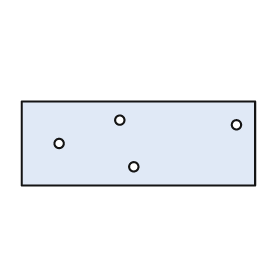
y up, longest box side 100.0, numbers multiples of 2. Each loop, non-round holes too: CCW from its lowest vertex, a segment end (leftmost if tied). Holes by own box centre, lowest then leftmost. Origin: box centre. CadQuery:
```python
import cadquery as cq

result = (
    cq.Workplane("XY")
    .moveTo(-50.0, -18.0)
    .lineTo(50.0, -18.0)
    .lineTo(50.0, 18.0)
    .lineTo(-50.0, 18.0)
    .close()
    .moveTo(-2.0, -10.0)
    .circle(2.0)
    .moveTo(-34.0, 0.0)
    .circle(2.0)
    .moveTo(42.0, 8.0)
    .circle(2.0)
    .moveTo(-8.0, 10.0)
    .circle(2.0)
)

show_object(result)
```